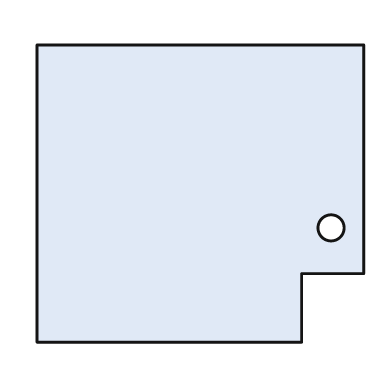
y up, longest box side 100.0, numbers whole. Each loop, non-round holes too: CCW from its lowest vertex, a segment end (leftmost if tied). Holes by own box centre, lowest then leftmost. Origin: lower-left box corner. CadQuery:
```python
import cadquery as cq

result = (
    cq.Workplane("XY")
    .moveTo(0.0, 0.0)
    .lineTo(81.0, 0.0)
    .lineTo(81.0, 21.0)
    .lineTo(100.0, 21.0)
    .lineTo(100.0, 91.0)
    .lineTo(0.0, 91.0)
    .close()
    .moveTo(90.0, 35.0)
    .circle(4.0)
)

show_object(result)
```